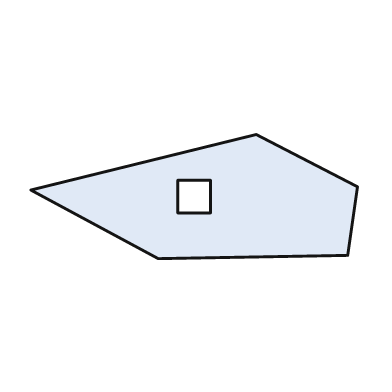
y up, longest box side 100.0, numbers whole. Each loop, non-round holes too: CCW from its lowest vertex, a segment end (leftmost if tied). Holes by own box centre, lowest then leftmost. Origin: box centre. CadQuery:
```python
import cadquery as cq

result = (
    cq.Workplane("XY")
    .moveTo(-11.0, -19.0)
    .lineTo(47.0, -18.0)
    .lineTo(50.0, 3.0)
    .lineTo(19.0, 19.0)
    .lineTo(-50.0, 2.0)
    .close()
    .moveTo(-5.0, -5.0)
    .lineTo(5.0, -5.0)
    .lineTo(5.0, 5.0)
    .lineTo(-5.0, 5.0)
    .close()
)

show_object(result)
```